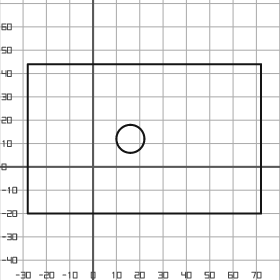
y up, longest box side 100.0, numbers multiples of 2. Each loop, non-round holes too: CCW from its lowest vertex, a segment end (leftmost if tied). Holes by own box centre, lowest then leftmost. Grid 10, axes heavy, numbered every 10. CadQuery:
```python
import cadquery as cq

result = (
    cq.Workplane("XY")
    .moveTo(-28.0, -20.0)
    .lineTo(72.0, -20.0)
    .lineTo(72.0, 44.0)
    .lineTo(-28.0, 44.0)
    .close()
    .moveTo(16.0, 12.0)
    .circle(6.0)
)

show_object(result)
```